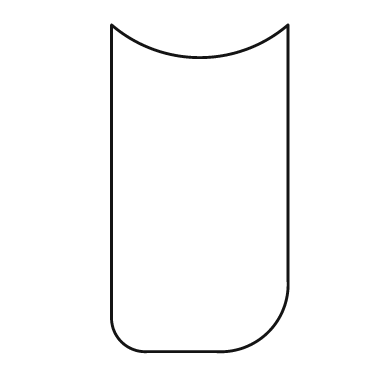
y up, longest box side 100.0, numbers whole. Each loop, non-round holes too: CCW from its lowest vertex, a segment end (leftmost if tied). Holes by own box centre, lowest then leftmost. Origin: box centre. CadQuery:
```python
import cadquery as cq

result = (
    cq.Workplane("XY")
    .moveTo(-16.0, -50.0)
    .lineTo(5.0, -50.0)
    .threePointArc((21.0, -44.0), (27.0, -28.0))
    .lineTo(27.0, 50.0)
    .threePointArc((0.0, 40.0), (-27.0, 50.0))
    .lineTo(-27.0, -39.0)
    .threePointArc((-24.0, -47.0), (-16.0, -50.0))
    .close()
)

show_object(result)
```